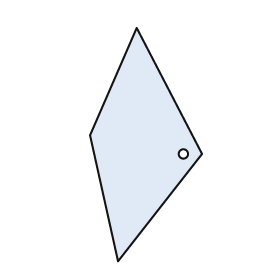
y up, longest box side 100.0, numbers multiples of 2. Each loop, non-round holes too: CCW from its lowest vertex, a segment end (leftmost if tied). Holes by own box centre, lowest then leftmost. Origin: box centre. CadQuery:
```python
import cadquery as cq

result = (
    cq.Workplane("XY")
    .moveTo(-12.0, -50.0)
    .lineTo(24.0, -4.0)
    .lineTo(-4.0, 50.0)
    .lineTo(-24.0, 4.0)
    .close()
    .moveTo(16.0, -4.0)
    .circle(2.0)
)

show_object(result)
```